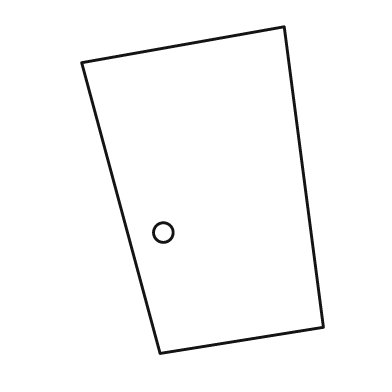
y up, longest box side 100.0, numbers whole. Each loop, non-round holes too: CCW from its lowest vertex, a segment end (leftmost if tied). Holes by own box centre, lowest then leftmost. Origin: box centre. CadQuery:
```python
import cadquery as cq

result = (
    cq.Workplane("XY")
    .moveTo(-13.0, -50.0)
    .lineTo(37.0, -42.0)
    .lineTo(25.0, 50.0)
    .lineTo(-37.0, 39.0)
    .close()
    .moveTo(-12.0, -13.0)
    .circle(3.0)
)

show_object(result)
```